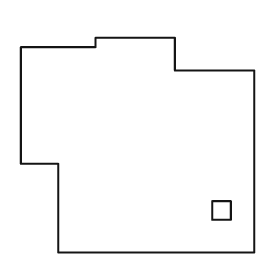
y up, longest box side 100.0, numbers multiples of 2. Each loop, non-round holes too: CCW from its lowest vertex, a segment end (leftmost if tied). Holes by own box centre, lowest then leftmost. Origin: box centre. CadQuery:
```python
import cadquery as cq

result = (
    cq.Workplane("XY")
    .moveTo(-34.0, -46.0)
    .lineTo(50.0, -46.0)
    .lineTo(50.0, 32.0)
    .lineTo(16.0, 32.0)
    .lineTo(16.0, 46.0)
    .lineTo(-18.0, 46.0)
    .lineTo(-18.0, 42.0)
    .lineTo(-50.0, 42.0)
    .lineTo(-50.0, -8.0)
    .lineTo(-34.0, -8.0)
    .close()
    .moveTo(32.0, -32.0)
    .lineTo(40.0, -32.0)
    .lineTo(40.0, -24.0)
    .lineTo(32.0, -24.0)
    .close()
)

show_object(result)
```